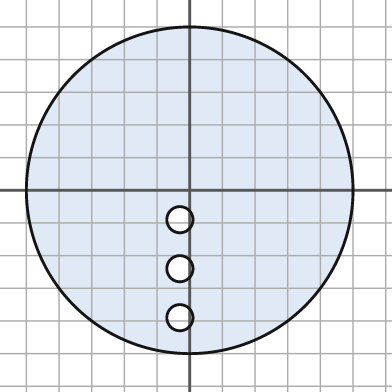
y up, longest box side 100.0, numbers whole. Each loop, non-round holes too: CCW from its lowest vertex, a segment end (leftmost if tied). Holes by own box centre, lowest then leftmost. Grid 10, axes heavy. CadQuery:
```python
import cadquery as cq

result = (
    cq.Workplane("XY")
    .moveTo(0.0, 0.0)
    .circle(50.0)
    .moveTo(-3.0, -39.0)
    .circle(4.0)
    .moveTo(-3.0, -24.0)
    .circle(4.0)
    .moveTo(-3.0, -9.0)
    .circle(4.0)
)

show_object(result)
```